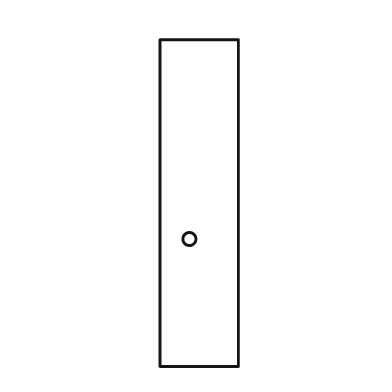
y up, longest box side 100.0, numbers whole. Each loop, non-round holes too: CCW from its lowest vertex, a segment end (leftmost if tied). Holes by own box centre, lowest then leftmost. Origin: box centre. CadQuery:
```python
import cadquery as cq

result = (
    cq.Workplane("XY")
    .moveTo(-12.0, -50.0)
    .lineTo(12.0, -50.0)
    .lineTo(12.0, 50.0)
    .lineTo(-12.0, 50.0)
    .close()
    .moveTo(-3.0, -11.0)
    .circle(2.0)
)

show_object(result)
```